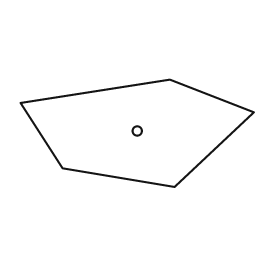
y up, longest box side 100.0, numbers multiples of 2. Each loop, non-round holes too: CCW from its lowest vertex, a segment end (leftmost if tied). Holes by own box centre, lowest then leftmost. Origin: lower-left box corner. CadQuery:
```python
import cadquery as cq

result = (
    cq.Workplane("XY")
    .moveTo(66.0, 0.0)
    .lineTo(100.0, 32.0)
    .lineTo(64.0, 46.0)
    .lineTo(0.0, 36.0)
    .lineTo(18.0, 8.0)
    .close()
    .moveTo(50.0, 24.0)
    .circle(2.0)
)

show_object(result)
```